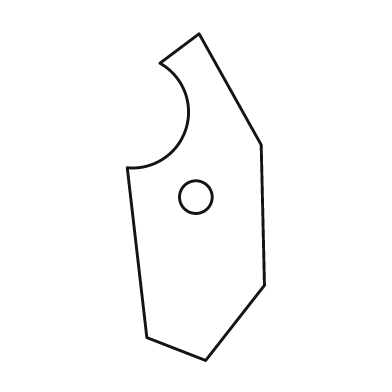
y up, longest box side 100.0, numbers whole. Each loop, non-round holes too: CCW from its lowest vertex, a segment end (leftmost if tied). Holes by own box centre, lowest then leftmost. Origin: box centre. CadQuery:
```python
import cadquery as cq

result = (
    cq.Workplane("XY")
    .moveTo(3.0, -50.0)
    .lineTo(21.0, -27.0)
    .lineTo(20.0, 16.0)
    .lineTo(1.0, 50.0)
    .lineTo(-11.0, 41.0)
    .threePointArc((-3.0, 21.0), (-21.0, 9.0))
    .lineTo(-15.0, -43.0)
    .close()
    .moveTo(0.0, 0.0)
    .circle(5.0)
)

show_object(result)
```